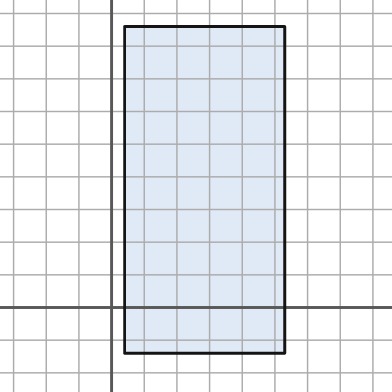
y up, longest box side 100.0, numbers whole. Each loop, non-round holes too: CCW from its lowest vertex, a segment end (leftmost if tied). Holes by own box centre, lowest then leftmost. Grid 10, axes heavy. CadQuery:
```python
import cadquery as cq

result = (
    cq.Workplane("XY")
    .moveTo(4.0, -14.0)
    .lineTo(53.0, -14.0)
    .lineTo(53.0, 86.0)
    .lineTo(4.0, 86.0)
    .close()
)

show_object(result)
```